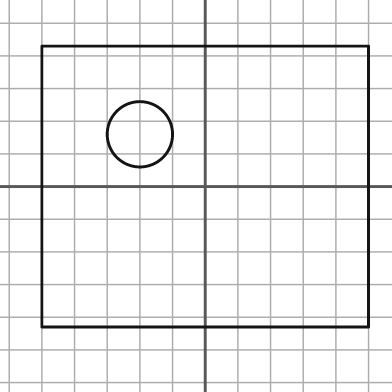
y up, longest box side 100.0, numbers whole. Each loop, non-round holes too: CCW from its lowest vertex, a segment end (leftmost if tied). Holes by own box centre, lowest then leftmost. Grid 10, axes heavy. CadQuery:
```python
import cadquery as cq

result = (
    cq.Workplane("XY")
    .moveTo(-50.0, -43.0)
    .lineTo(50.0, -43.0)
    .lineTo(50.0, 43.0)
    .lineTo(-50.0, 43.0)
    .close()
    .moveTo(-20.0, 16.0)
    .circle(10.0)
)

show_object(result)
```